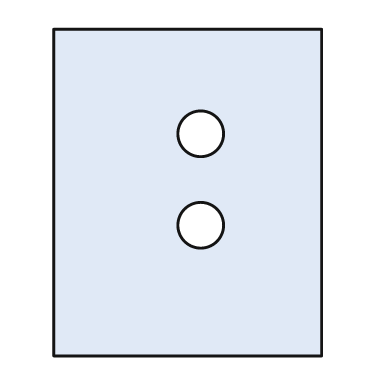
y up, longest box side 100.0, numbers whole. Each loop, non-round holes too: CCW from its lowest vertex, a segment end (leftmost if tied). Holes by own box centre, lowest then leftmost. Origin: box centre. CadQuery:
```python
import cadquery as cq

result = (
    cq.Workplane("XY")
    .moveTo(-41.0, -50.0)
    .lineTo(41.0, -50.0)
    .lineTo(41.0, 50.0)
    .lineTo(-41.0, 50.0)
    .close()
    .moveTo(4.0, -10.0)
    .circle(7.0)
    .moveTo(4.0, 18.0)
    .circle(7.0)
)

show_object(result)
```